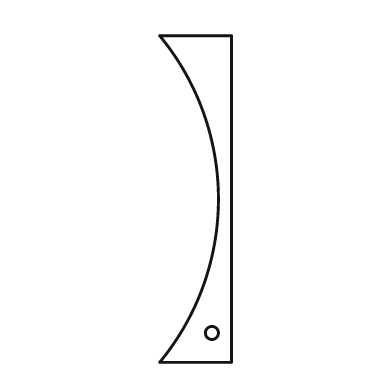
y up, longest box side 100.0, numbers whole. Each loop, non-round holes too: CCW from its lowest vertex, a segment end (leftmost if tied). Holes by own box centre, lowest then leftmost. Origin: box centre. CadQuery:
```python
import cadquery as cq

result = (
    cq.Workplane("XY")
    .moveTo(-11.0, -50.0)
    .lineTo(11.0, -50.0)
    .lineTo(11.0, 50.0)
    .lineTo(-11.0, 50.0)
    .threePointArc((7.0, 0.0), (-11.0, -50.0))
    .close()
    .moveTo(5.0, -41.0)
    .circle(2.0)
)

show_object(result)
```